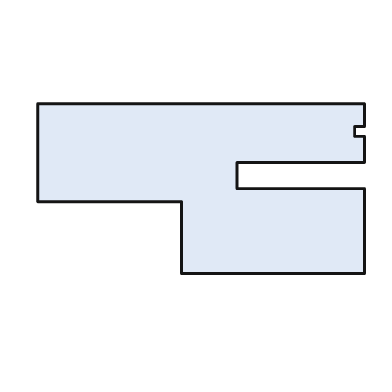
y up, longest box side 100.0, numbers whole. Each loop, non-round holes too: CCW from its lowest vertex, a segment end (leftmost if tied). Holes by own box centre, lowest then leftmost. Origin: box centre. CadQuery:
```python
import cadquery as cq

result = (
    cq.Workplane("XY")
    .moveTo(-6.0, -26.0)
    .lineTo(50.0, -26.0)
    .lineTo(50.0, 0.0)
    .lineTo(11.0, 0.0)
    .lineTo(11.0, 8.0)
    .lineTo(50.0, 8.0)
    .lineTo(50.0, 16.0)
    .lineTo(47.0, 16.0)
    .lineTo(47.0, 19.0)
    .lineTo(50.0, 19.0)
    .lineTo(50.0, 26.0)
    .lineTo(-50.0, 26.0)
    .lineTo(-50.0, -4.0)
    .lineTo(-6.0, -4.0)
    .close()
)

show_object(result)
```